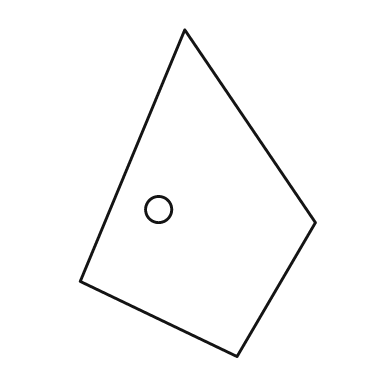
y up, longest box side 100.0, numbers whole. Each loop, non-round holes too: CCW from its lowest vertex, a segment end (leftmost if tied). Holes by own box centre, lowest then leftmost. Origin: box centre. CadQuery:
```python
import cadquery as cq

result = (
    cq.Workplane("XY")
    .moveTo(12.0, -50.0)
    .lineTo(36.0, -9.0)
    .lineTo(-4.0, 50.0)
    .lineTo(-36.0, -27.0)
    .close()
    .moveTo(-12.0, -5.0)
    .circle(4.0)
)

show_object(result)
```